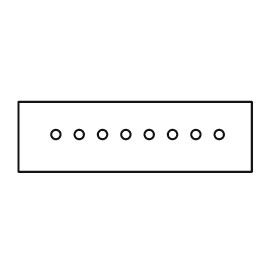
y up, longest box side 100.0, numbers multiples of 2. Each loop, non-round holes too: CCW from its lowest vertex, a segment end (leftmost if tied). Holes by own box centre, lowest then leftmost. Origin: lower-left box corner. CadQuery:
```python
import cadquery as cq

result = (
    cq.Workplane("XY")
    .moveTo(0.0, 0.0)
    .lineTo(100.0, 0.0)
    .lineTo(100.0, 30.0)
    .lineTo(0.0, 30.0)
    .close()
    .moveTo(16.0, 16.0)
    .circle(2.0)
    .moveTo(26.0, 16.0)
    .circle(2.0)
    .moveTo(36.0, 16.0)
    .circle(2.0)
    .moveTo(46.0, 16.0)
    .circle(2.0)
    .moveTo(56.0, 16.0)
    .circle(2.0)
    .moveTo(66.0, 16.0)
    .circle(2.0)
    .moveTo(76.0, 16.0)
    .circle(2.0)
    .moveTo(86.0, 16.0)
    .circle(2.0)
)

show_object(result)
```